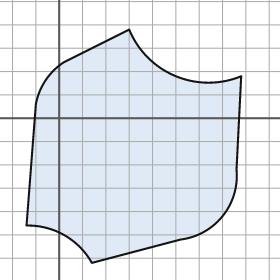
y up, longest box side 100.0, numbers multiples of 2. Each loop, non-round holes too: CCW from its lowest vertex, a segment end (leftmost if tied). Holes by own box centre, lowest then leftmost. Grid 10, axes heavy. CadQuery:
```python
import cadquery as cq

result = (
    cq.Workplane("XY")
    .moveTo(14.0, -62.0)
    .lineTo(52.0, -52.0)
    .threePointArc((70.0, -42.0), (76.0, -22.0))
    .lineTo(78.0, 18.0)
    .threePointArc((50.0, 18.0), (30.0, 38.0))
    .lineTo(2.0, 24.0)
    .threePointArc((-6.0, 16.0), (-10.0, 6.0))
    .lineTo(-14.0, -46.0)
    .threePointArc((2.0, -50.0), (14.0, -62.0))
    .close()
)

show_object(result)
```